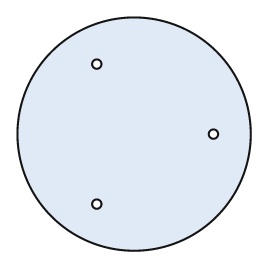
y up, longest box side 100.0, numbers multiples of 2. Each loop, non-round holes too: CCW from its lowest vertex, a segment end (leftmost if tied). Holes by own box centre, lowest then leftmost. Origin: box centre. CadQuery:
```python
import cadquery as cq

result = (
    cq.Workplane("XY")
    .moveTo(0.0, 0.0)
    .circle(50.0)
    .moveTo(-16.0, -30.0)
    .circle(2.0)
    .moveTo(34.0, 0.0)
    .circle(2.0)
    .moveTo(-16.0, 30.0)
    .circle(2.0)
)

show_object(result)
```